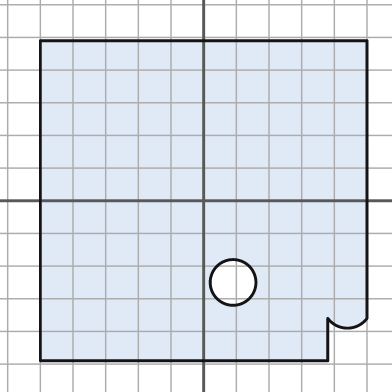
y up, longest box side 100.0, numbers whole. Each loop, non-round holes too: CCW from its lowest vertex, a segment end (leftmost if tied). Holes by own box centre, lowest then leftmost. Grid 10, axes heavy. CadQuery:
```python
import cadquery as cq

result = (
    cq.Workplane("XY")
    .moveTo(-50.0, -49.0)
    .lineTo(38.0, -49.0)
    .lineTo(38.0, -36.0)
    .threePointArc((44.0, -39.0), (50.0, -36.0))
    .lineTo(50.0, 49.0)
    .lineTo(-50.0, 49.0)
    .close()
    .moveTo(9.0, -25.0)
    .circle(7.0)
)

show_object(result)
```